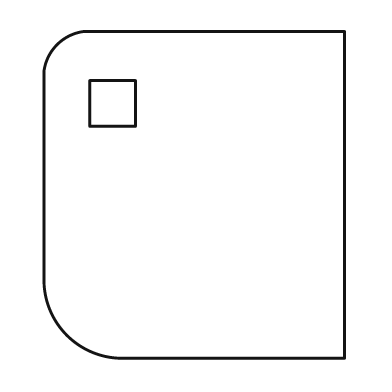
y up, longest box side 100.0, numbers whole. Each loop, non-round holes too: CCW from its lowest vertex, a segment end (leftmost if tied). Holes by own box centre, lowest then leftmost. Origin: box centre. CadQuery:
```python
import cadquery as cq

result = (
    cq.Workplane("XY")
    .moveTo(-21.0, -50.0)
    .lineTo(46.0, -50.0)
    .lineTo(46.0, 50.0)
    .lineTo(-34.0, 50.0)
    .threePointArc((-42.0, 46.0), (-46.0, 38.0))
    .lineTo(-46.0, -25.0)
    .threePointArc((-39.0, -43.0), (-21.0, -50.0))
    .close()
    .moveTo(-32.0, 21.0)
    .lineTo(-18.0, 21.0)
    .lineTo(-18.0, 35.0)
    .lineTo(-32.0, 35.0)
    .close()
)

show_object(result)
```